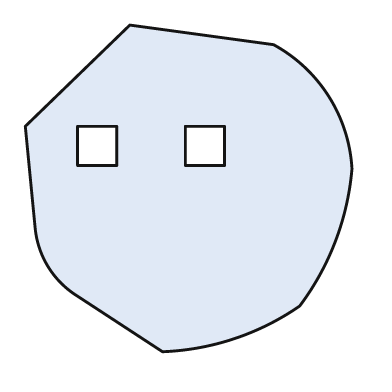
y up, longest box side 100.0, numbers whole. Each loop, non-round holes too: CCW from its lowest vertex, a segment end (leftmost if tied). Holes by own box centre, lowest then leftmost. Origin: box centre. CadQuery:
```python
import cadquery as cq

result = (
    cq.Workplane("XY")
    .moveTo(-8.0, -50.0)
    .threePointArc((14.0, -46.0), (34.0, -36.0))
    .threePointArc((45.0, -16.0), (50.0, 6.0))
    .threePointArc((43.0, 28.0), (26.0, 44.0))
    .lineTo(-18.0, 50.0)
    .lineTo(-50.0, 19.0)
    .lineTo(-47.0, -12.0)
    .threePointArc((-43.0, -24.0), (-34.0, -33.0))
    .close()
    .moveTo(-34.0, 7.0)
    .lineTo(-22.0, 7.0)
    .lineTo(-22.0, 19.0)
    .lineTo(-34.0, 19.0)
    .close()
    .moveTo(-1.0, 7.0)
    .lineTo(11.0, 7.0)
    .lineTo(11.0, 19.0)
    .lineTo(-1.0, 19.0)
    .close()
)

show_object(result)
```